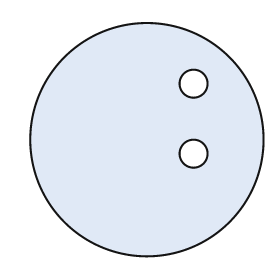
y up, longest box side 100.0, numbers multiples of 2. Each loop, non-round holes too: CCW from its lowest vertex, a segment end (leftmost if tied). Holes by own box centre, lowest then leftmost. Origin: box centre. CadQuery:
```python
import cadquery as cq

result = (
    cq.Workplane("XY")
    .moveTo(0.0, 0.0)
    .circle(50.0)
    .moveTo(20.0, -6.0)
    .circle(6.0)
    .moveTo(20.0, 24.0)
    .circle(6.0)
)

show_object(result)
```